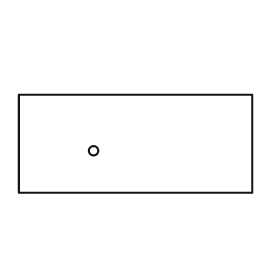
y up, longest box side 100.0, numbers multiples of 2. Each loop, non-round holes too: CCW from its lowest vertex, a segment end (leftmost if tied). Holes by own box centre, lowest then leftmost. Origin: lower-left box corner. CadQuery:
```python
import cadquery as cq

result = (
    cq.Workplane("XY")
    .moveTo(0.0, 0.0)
    .lineTo(100.0, 0.0)
    .lineTo(100.0, 42.0)
    .lineTo(0.0, 42.0)
    .close()
    .moveTo(32.0, 18.0)
    .circle(2.0)
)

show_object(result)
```